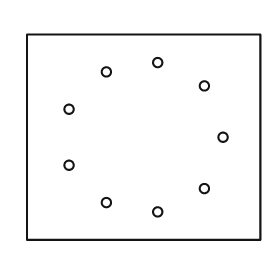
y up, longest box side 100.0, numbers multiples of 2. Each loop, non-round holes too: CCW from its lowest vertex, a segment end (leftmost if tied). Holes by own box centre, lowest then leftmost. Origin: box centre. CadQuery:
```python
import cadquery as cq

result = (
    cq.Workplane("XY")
    .moveTo(-50.0, -44.0)
    .lineTo(50.0, -44.0)
    .lineTo(50.0, 44.0)
    .lineTo(-50.0, 44.0)
    .close()
    .moveTo(6.0, -32.0)
    .circle(2.0)
    .moveTo(-16.0, -28.0)
    .circle(2.0)
    .moveTo(26.0, -22.0)
    .circle(2.0)
    .moveTo(-32.0, -12.0)
    .circle(2.0)
    .moveTo(34.0, 0.0)
    .circle(2.0)
    .moveTo(-32.0, 12.0)
    .circle(2.0)
    .moveTo(26.0, 22.0)
    .circle(2.0)
    .moveTo(-16.0, 28.0)
    .circle(2.0)
    .moveTo(6.0, 32.0)
    .circle(2.0)
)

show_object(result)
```